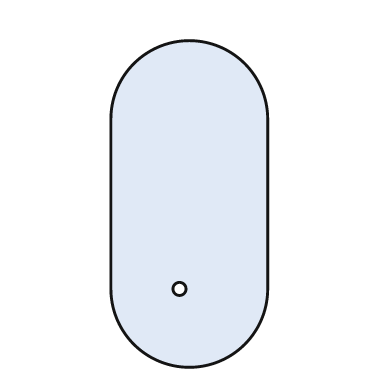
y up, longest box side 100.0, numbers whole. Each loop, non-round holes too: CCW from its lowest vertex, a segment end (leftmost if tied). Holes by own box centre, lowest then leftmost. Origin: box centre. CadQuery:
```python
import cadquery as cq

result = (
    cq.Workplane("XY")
    .moveTo(-24.0, -26.0)
    .threePointArc((0.0, -50.0), (24.0, -26.0))
    .lineTo(24.0, 26.0)
    .threePointArc((0.0, 50.0), (-24.0, 26.0))
    .close()
    .moveTo(-3.0, -26.0)
    .circle(2.0)
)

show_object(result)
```